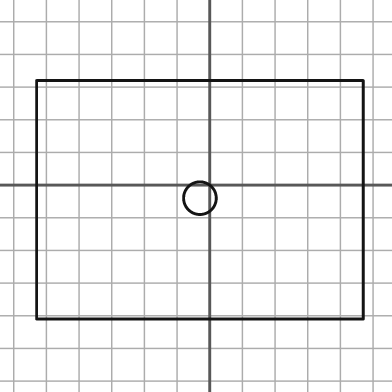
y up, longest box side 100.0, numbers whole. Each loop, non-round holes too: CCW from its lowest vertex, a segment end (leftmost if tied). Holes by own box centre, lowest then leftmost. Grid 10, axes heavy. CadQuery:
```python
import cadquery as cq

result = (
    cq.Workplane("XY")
    .moveTo(-53.0, -41.0)
    .lineTo(47.0, -41.0)
    .lineTo(47.0, 32.0)
    .lineTo(-53.0, 32.0)
    .close()
    .moveTo(-3.0, -4.0)
    .circle(5.0)
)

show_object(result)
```